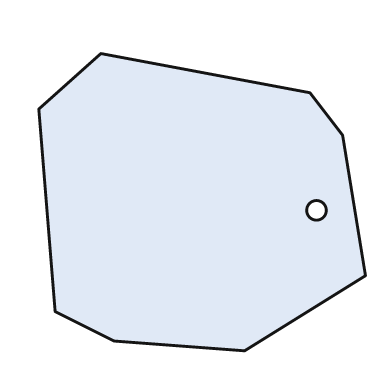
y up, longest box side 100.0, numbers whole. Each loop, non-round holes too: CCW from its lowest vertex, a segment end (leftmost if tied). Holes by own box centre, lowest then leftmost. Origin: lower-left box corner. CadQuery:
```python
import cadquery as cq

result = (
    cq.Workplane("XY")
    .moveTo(63.0, 0.0)
    .lineTo(100.0, 23.0)
    .lineTo(93.0, 66.0)
    .lineTo(83.0, 79.0)
    .lineTo(19.0, 91.0)
    .lineTo(0.0, 74.0)
    .lineTo(5.0, 12.0)
    .lineTo(23.0, 3.0)
    .close()
    .moveTo(85.0, 43.0)
    .circle(3.0)
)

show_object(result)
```